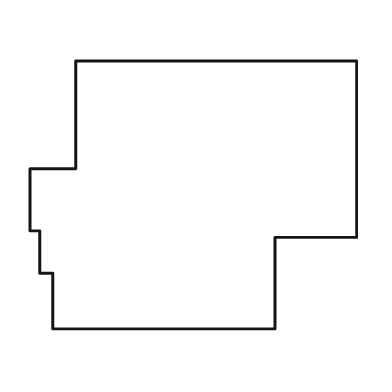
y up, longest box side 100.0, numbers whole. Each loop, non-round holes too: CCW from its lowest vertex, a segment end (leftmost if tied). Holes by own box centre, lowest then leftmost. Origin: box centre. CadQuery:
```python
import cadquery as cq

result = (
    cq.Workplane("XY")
    .moveTo(-43.0, -41.0)
    .lineTo(25.0, -41.0)
    .lineTo(25.0, -13.0)
    .lineTo(50.0, -13.0)
    .lineTo(50.0, 41.0)
    .lineTo(-36.0, 41.0)
    .lineTo(-36.0, 8.0)
    .lineTo(-50.0, 8.0)
    .lineTo(-50.0, -11.0)
    .lineTo(-47.0, -11.0)
    .lineTo(-47.0, -24.0)
    .lineTo(-43.0, -24.0)
    .close()
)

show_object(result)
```